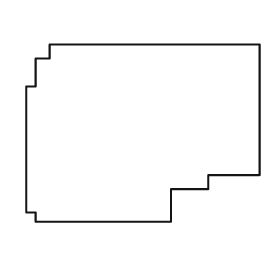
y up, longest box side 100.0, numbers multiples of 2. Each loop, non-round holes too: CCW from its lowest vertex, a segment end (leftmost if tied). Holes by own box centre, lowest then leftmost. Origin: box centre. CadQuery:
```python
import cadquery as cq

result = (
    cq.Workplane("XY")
    .moveTo(-46.0, -38.0)
    .lineTo(12.0, -38.0)
    .lineTo(12.0, -24.0)
    .lineTo(28.0, -24.0)
    .lineTo(28.0, -18.0)
    .lineTo(50.0, -18.0)
    .lineTo(50.0, 38.0)
    .lineTo(-40.0, 38.0)
    .lineTo(-40.0, 32.0)
    .lineTo(-46.0, 32.0)
    .lineTo(-46.0, 20.0)
    .lineTo(-50.0, 20.0)
    .lineTo(-50.0, -34.0)
    .lineTo(-46.0, -34.0)
    .close()
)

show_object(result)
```